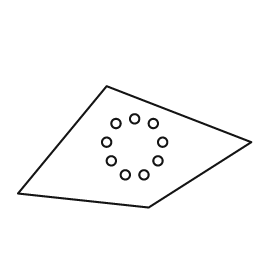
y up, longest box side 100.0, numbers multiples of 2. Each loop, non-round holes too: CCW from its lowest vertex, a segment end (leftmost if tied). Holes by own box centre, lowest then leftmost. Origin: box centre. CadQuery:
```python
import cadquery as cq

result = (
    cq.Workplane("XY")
    .moveTo(6.0, -26.0)
    .lineTo(50.0, 2.0)
    .lineTo(-12.0, 26.0)
    .lineTo(-50.0, -20.0)
    .close()
    .moveTo(-4.0, -12.0)
    .circle(2.0)
    .moveTo(4.0, -12.0)
    .circle(2.0)
    .moveTo(-10.0, -6.0)
    .circle(2.0)
    .moveTo(10.0, -6.0)
    .circle(2.0)
    .moveTo(-12.0, 2.0)
    .circle(2.0)
    .moveTo(12.0, 2.0)
    .circle(2.0)
    .moveTo(-8.0, 10.0)
    .circle(2.0)
    .moveTo(8.0, 10.0)
    .circle(2.0)
    .moveTo(0.0, 12.0)
    .circle(2.0)
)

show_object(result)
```